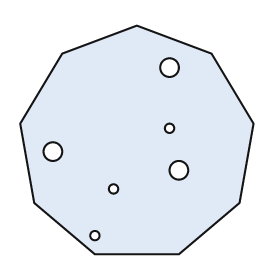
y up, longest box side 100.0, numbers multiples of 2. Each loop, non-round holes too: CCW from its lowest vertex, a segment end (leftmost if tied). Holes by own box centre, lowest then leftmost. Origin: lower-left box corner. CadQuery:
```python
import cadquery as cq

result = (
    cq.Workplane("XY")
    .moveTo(32.0, 0.0)
    .lineTo(68.0, 0.0)
    .lineTo(94.0, 22.0)
    .lineTo(100.0, 56.0)
    .lineTo(82.0, 86.0)
    .lineTo(50.0, 98.0)
    .lineTo(18.0, 86.0)
    .lineTo(0.0, 56.0)
    .lineTo(6.0, 22.0)
    .close()
    .moveTo(32.0, 8.0)
    .circle(2.0)
    .moveTo(40.0, 28.0)
    .circle(2.0)
    .moveTo(68.0, 36.0)
    .circle(4.0)
    .moveTo(14.0, 44.0)
    .circle(4.0)
    .moveTo(64.0, 54.0)
    .circle(2.0)
    .moveTo(64.0, 80.0)
    .circle(4.0)
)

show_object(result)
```